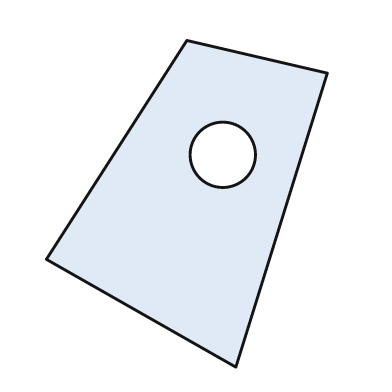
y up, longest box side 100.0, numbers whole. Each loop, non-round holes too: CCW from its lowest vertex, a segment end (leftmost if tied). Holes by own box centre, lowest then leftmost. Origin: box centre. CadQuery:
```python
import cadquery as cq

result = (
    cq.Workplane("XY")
    .moveTo(15.0, -50.0)
    .lineTo(43.0, 40.0)
    .lineTo(0.0, 50.0)
    .lineTo(-43.0, -17.0)
    .close()
    .moveTo(11.0, 15.0)
    .circle(10.0)
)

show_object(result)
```